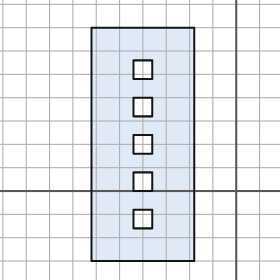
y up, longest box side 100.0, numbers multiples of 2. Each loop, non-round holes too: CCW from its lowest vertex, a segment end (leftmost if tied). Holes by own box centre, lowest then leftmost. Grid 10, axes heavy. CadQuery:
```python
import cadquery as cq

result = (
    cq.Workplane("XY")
    .moveTo(-62.0, -30.0)
    .lineTo(-18.0, -30.0)
    .lineTo(-18.0, 70.0)
    .lineTo(-62.0, 70.0)
    .close()
    .moveTo(-44.0, -16.0)
    .lineTo(-36.0, -16.0)
    .lineTo(-36.0, -8.0)
    .lineTo(-44.0, -8.0)
    .close()
    .moveTo(-44.0, 0.0)
    .lineTo(-36.0, 0.0)
    .lineTo(-36.0, 8.0)
    .lineTo(-44.0, 8.0)
    .close()
    .moveTo(-44.0, 16.0)
    .lineTo(-36.0, 16.0)
    .lineTo(-36.0, 24.0)
    .lineTo(-44.0, 24.0)
    .close()
    .moveTo(-44.0, 32.0)
    .lineTo(-36.0, 32.0)
    .lineTo(-36.0, 40.0)
    .lineTo(-44.0, 40.0)
    .close()
    .moveTo(-44.0, 48.0)
    .lineTo(-36.0, 48.0)
    .lineTo(-36.0, 56.0)
    .lineTo(-44.0, 56.0)
    .close()
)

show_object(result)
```